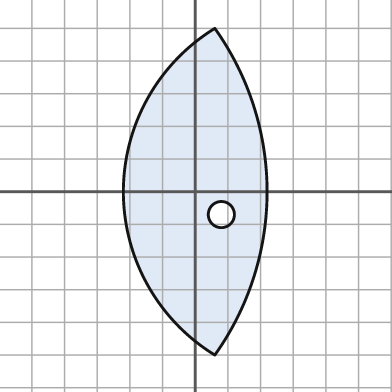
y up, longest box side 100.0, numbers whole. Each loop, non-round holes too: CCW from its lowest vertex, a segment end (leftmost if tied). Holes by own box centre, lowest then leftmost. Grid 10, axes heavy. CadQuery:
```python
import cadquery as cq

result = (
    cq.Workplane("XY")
    .moveTo(6.0, -50.0)
    .threePointArc((22.0, 0.0), (6.0, 50.0))
    .threePointArc((-22.0, 0.0), (6.0, -50.0))
    .close()
    .moveTo(8.0, -7.0)
    .circle(4.0)
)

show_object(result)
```